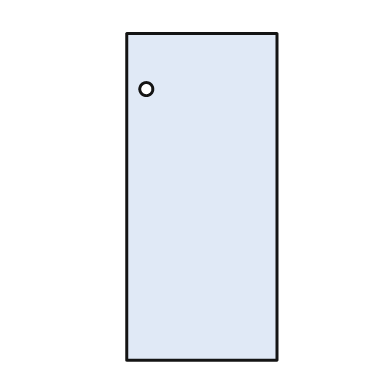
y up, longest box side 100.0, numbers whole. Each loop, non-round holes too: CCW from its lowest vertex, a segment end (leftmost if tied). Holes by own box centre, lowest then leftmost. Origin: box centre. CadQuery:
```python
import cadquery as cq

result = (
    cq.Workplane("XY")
    .moveTo(-23.0, -50.0)
    .lineTo(23.0, -50.0)
    .lineTo(23.0, 50.0)
    .lineTo(-23.0, 50.0)
    .close()
    .moveTo(-17.0, 33.0)
    .circle(2.0)
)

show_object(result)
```